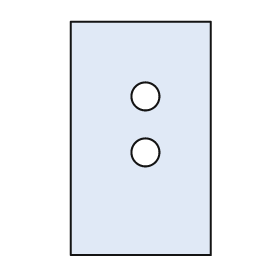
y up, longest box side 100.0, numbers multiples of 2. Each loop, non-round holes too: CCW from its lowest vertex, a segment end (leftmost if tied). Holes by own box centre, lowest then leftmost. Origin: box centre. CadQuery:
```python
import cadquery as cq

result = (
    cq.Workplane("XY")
    .moveTo(-30.0, -50.0)
    .lineTo(30.0, -50.0)
    .lineTo(30.0, 50.0)
    .lineTo(-30.0, 50.0)
    .close()
    .moveTo(2.0, -6.0)
    .circle(6.0)
    .moveTo(2.0, 18.0)
    .circle(6.0)
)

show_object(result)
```